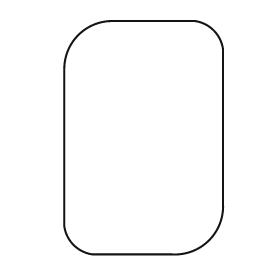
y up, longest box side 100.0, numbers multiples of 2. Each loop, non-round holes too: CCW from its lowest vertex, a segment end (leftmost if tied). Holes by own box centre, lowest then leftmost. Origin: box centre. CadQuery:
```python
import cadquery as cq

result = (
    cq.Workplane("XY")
    .moveTo(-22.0, -50.0)
    .lineTo(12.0, -50.0)
    .threePointArc((28.0, -44.0), (34.0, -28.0))
    .lineTo(34.0, 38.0)
    .threePointArc((30.0, 46.0), (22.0, 50.0))
    .lineTo(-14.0, 50.0)
    .threePointArc((-28.0, 44.0), (-34.0, 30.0))
    .lineTo(-34.0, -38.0)
    .threePointArc((-30.0, -46.0), (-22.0, -50.0))
    .close()
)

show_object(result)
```